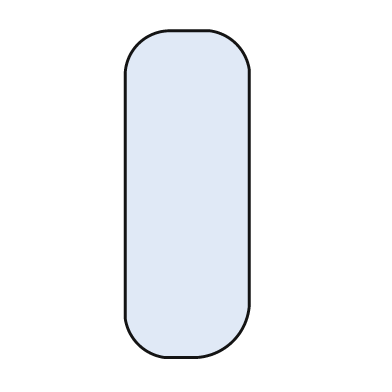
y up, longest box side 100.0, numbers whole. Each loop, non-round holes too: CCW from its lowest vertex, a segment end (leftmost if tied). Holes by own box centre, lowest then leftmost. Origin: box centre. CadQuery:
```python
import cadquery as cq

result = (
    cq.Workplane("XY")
    .moveTo(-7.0, -50.0)
    .lineTo(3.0, -50.0)
    .threePointArc((14.0, -45.0), (19.0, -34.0))
    .lineTo(19.0, 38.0)
    .threePointArc((15.0, 46.0), (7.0, 50.0))
    .lineTo(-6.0, 50.0)
    .threePointArc((-15.0, 46.0), (-19.0, 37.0))
    .lineTo(-19.0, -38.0)
    .threePointArc((-15.0, -46.0), (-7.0, -50.0))
    .close()
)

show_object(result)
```